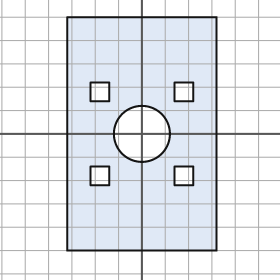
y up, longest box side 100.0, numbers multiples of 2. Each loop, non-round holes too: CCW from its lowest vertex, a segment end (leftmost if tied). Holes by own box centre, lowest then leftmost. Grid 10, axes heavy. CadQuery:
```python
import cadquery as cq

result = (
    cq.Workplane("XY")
    .moveTo(-32.0, -50.0)
    .lineTo(32.0, -50.0)
    .lineTo(32.0, 50.0)
    .lineTo(-32.0, 50.0)
    .close()
    .moveTo(-22.0, -22.0)
    .lineTo(-14.0, -22.0)
    .lineTo(-14.0, -14.0)
    .lineTo(-22.0, -14.0)
    .close()
    .moveTo(14.0, -22.0)
    .lineTo(22.0, -22.0)
    .lineTo(22.0, -14.0)
    .lineTo(14.0, -14.0)
    .close()
    .moveTo(0.0, 0.0)
    .circle(12.0)
    .moveTo(-22.0, 14.0)
    .lineTo(-14.0, 14.0)
    .lineTo(-14.0, 22.0)
    .lineTo(-22.0, 22.0)
    .close()
    .moveTo(14.0, 14.0)
    .lineTo(22.0, 14.0)
    .lineTo(22.0, 22.0)
    .lineTo(14.0, 22.0)
    .close()
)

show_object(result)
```